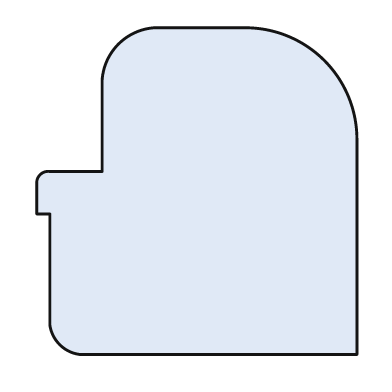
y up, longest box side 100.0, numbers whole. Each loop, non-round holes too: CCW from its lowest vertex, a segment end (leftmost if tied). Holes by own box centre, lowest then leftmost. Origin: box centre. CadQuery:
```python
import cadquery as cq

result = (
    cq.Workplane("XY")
    .moveTo(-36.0, -50.0)
    .lineTo(49.0, -50.0)
    .lineTo(49.0, 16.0)
    .threePointArc((39.0, 40.0), (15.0, 50.0))
    .lineTo(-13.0, 50.0)
    .threePointArc((-24.0, 45.0), (-29.0, 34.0))
    .lineTo(-29.0, 6.0)
    .lineTo(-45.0, 6.0)
    .threePointArc((-48.0, 5.0), (-49.0, 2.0))
    .lineTo(-49.0, -7.0)
    .lineTo(-45.0, -7.0)
    .lineTo(-45.0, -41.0)
    .threePointArc((-42.0, -47.0), (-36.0, -50.0))
    .close()
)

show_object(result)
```